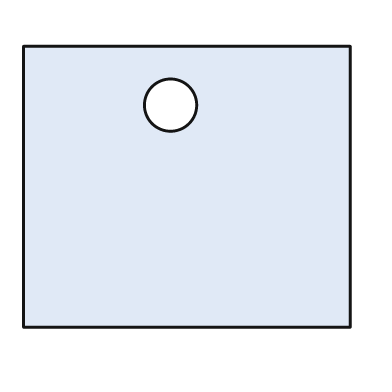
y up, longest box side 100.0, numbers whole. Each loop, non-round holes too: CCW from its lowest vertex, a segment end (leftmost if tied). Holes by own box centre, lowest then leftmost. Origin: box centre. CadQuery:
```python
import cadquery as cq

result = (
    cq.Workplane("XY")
    .moveTo(-50.0, -43.0)
    .lineTo(50.0, -43.0)
    .lineTo(50.0, 43.0)
    .lineTo(-50.0, 43.0)
    .close()
    .moveTo(-5.0, 25.0)
    .circle(8.0)
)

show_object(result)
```